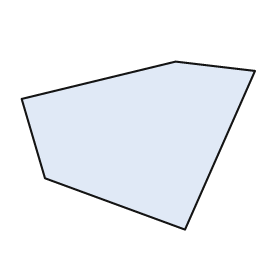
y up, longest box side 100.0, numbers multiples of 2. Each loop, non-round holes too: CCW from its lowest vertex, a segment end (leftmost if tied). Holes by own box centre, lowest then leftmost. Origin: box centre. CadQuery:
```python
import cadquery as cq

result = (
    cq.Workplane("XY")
    .moveTo(20.0, -36.0)
    .lineTo(50.0, 32.0)
    .lineTo(16.0, 36.0)
    .lineTo(-50.0, 20.0)
    .lineTo(-40.0, -14.0)
    .close()
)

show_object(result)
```